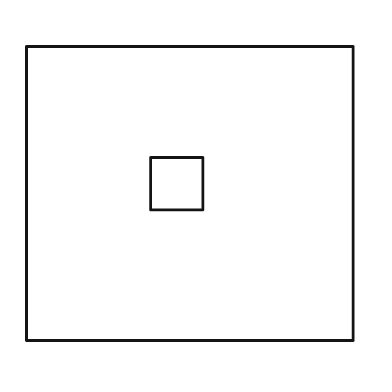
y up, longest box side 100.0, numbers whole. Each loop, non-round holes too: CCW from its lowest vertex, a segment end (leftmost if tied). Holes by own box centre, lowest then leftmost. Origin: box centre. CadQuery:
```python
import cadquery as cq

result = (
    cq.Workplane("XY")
    .moveTo(-50.0, -45.0)
    .lineTo(50.0, -45.0)
    .lineTo(50.0, 45.0)
    .lineTo(-50.0, 45.0)
    .close()
    .moveTo(-12.0, -5.0)
    .lineTo(4.0, -5.0)
    .lineTo(4.0, 11.0)
    .lineTo(-12.0, 11.0)
    .close()
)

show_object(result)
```